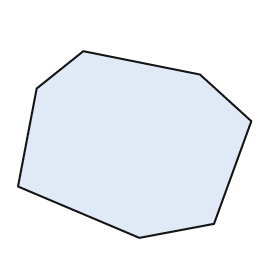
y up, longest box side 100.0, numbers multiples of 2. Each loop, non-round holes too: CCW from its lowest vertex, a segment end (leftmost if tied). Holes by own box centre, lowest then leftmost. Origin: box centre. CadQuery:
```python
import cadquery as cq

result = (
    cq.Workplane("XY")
    .moveTo(2.0, -40.0)
    .lineTo(34.0, -34.0)
    .lineTo(50.0, 10.0)
    .lineTo(28.0, 30.0)
    .lineTo(-22.0, 40.0)
    .lineTo(-42.0, 24.0)
    .lineTo(-50.0, -18.0)
    .close()
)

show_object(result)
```